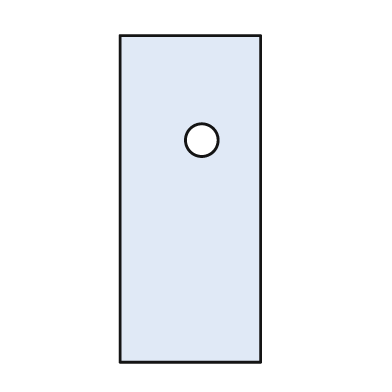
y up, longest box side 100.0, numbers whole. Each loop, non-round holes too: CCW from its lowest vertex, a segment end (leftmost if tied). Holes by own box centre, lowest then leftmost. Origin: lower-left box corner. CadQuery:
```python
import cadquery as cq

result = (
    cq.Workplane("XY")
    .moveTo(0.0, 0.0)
    .lineTo(43.0, 0.0)
    .lineTo(43.0, 100.0)
    .lineTo(0.0, 100.0)
    .close()
    .moveTo(25.0, 68.0)
    .circle(5.0)
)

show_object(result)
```